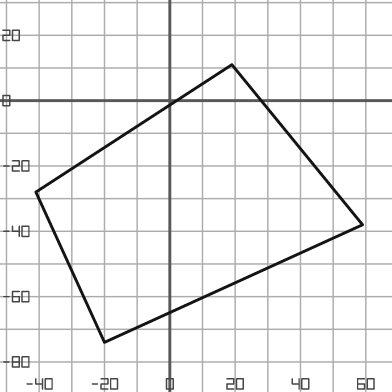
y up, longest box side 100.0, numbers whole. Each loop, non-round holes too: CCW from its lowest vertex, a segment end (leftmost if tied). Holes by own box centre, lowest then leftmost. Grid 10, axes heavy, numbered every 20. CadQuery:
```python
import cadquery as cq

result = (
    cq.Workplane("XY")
    .moveTo(-20.0, -74.0)
    .lineTo(59.0, -38.0)
    .lineTo(19.0, 11.0)
    .lineTo(-41.0, -28.0)
    .close()
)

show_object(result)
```